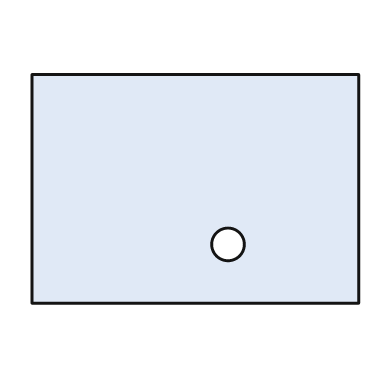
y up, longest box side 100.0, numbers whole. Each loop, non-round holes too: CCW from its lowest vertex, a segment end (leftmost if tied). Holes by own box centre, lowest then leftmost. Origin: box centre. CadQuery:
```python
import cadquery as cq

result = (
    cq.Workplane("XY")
    .moveTo(-50.0, -35.0)
    .lineTo(50.0, -35.0)
    .lineTo(50.0, 35.0)
    .lineTo(-50.0, 35.0)
    .close()
    .moveTo(10.0, -17.0)
    .circle(5.0)
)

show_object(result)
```